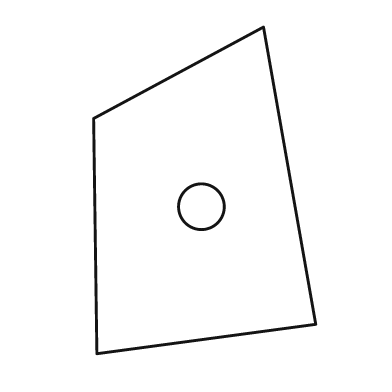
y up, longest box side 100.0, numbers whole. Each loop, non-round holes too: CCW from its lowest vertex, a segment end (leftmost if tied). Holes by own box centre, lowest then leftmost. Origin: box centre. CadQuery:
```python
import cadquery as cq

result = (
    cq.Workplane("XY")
    .moveTo(-33.0, -50.0)
    .lineTo(34.0, -41.0)
    .lineTo(18.0, 50.0)
    .lineTo(-34.0, 22.0)
    .close()
    .moveTo(-1.0, -5.0)
    .circle(7.0)
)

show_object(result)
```